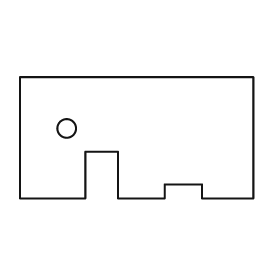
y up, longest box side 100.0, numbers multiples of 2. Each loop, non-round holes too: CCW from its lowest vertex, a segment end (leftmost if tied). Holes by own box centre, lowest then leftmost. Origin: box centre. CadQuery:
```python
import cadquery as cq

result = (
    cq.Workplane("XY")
    .moveTo(-50.0, -26.0)
    .lineTo(-22.0, -26.0)
    .lineTo(-22.0, -6.0)
    .lineTo(-8.0, -6.0)
    .lineTo(-8.0, -26.0)
    .lineTo(12.0, -26.0)
    .lineTo(12.0, -20.0)
    .lineTo(28.0, -20.0)
    .lineTo(28.0, -26.0)
    .lineTo(50.0, -26.0)
    .lineTo(50.0, 26.0)
    .lineTo(-50.0, 26.0)
    .close()
    .moveTo(-30.0, 4.0)
    .circle(4.0)
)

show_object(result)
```